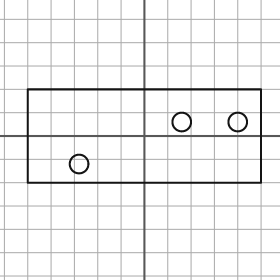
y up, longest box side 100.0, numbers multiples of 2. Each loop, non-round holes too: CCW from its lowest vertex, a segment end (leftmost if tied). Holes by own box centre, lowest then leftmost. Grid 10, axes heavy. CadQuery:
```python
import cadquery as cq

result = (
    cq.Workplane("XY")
    .moveTo(-50.0, -20.0)
    .lineTo(50.0, -20.0)
    .lineTo(50.0, 20.0)
    .lineTo(-50.0, 20.0)
    .close()
    .moveTo(-28.0, -12.0)
    .circle(4.0)
    .moveTo(16.0, 6.0)
    .circle(4.0)
    .moveTo(40.0, 6.0)
    .circle(4.0)
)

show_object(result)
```